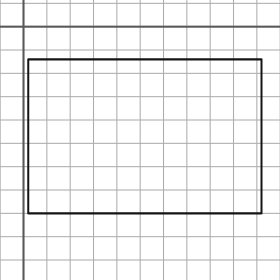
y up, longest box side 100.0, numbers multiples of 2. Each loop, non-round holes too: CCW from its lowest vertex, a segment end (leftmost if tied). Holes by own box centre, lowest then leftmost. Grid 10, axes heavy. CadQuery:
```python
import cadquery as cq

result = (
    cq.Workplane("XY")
    .moveTo(2.0, -80.0)
    .lineTo(102.0, -80.0)
    .lineTo(102.0, -14.0)
    .lineTo(2.0, -14.0)
    .close()
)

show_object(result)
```